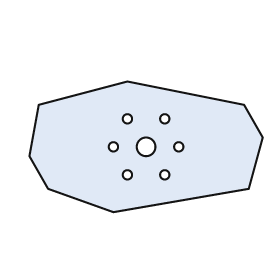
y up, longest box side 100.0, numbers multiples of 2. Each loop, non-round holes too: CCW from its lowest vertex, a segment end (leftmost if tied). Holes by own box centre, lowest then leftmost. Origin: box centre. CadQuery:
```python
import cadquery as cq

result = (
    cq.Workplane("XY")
    .moveTo(-14.0, -28.0)
    .lineTo(44.0, -18.0)
    .lineTo(50.0, 4.0)
    .lineTo(42.0, 18.0)
    .lineTo(-8.0, 28.0)
    .lineTo(-46.0, 18.0)
    .lineTo(-50.0, -4.0)
    .lineTo(-42.0, -18.0)
    .close()
    .moveTo(-8.0, -12.0)
    .circle(2.0)
    .moveTo(8.0, -12.0)
    .circle(2.0)
    .moveTo(-14.0, 0.0)
    .circle(2.0)
    .moveTo(0.0, 0.0)
    .circle(4.0)
    .moveTo(14.0, 0.0)
    .circle(2.0)
    .moveTo(-8.0, 12.0)
    .circle(2.0)
    .moveTo(8.0, 12.0)
    .circle(2.0)
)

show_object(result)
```